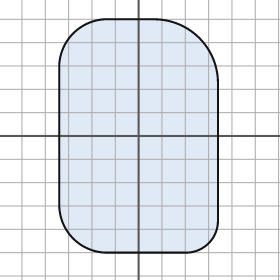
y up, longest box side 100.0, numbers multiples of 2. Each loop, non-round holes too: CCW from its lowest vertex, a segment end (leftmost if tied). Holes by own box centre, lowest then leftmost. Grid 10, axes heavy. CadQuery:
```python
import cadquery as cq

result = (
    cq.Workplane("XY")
    .moveTo(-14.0, -50.0)
    .lineTo(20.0, -50.0)
    .threePointArc((30.0, -46.0), (34.0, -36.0))
    .lineTo(34.0, 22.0)
    .threePointArc((26.0, 42.0), (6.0, 50.0))
    .lineTo(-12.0, 50.0)
    .threePointArc((-28.0, 44.0), (-34.0, 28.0))
    .lineTo(-34.0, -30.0)
    .threePointArc((-28.0, -44.0), (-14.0, -50.0))
    .close()
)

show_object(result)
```